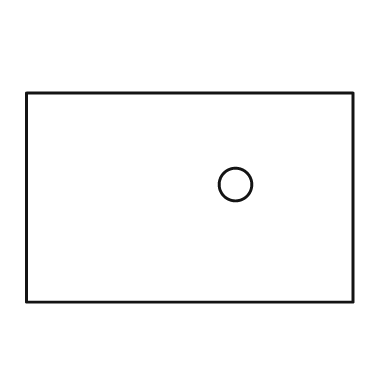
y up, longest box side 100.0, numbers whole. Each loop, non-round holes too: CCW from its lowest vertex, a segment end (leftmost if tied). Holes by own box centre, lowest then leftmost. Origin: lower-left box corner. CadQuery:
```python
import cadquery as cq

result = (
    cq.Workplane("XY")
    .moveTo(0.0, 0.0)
    .lineTo(100.0, 0.0)
    .lineTo(100.0, 64.0)
    .lineTo(0.0, 64.0)
    .close()
    .moveTo(64.0, 36.0)
    .circle(5.0)
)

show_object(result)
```